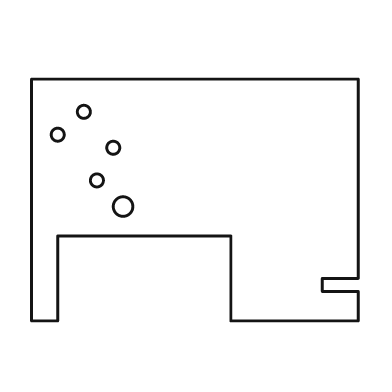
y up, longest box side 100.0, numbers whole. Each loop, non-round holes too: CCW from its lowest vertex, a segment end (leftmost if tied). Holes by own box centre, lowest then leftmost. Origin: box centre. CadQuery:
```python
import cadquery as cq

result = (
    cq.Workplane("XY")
    .moveTo(-50.0, -37.0)
    .lineTo(-42.0, -37.0)
    .lineTo(-42.0, -11.0)
    .lineTo(11.0, -11.0)
    .lineTo(11.0, -37.0)
    .lineTo(50.0, -37.0)
    .lineTo(50.0, -28.0)
    .lineTo(39.0, -28.0)
    .lineTo(39.0, -24.0)
    .lineTo(50.0, -24.0)
    .lineTo(50.0, 37.0)
    .lineTo(-50.0, 37.0)
    .close()
    .moveTo(-22.0, -2.0)
    .circle(3.0)
    .moveTo(-30.0, 6.0)
    .circle(2.0)
    .moveTo(-25.0, 16.0)
    .circle(2.0)
    .moveTo(-42.0, 20.0)
    .circle(2.0)
    .moveTo(-34.0, 27.0)
    .circle(2.0)
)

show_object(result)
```